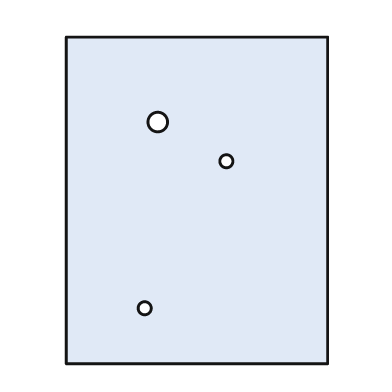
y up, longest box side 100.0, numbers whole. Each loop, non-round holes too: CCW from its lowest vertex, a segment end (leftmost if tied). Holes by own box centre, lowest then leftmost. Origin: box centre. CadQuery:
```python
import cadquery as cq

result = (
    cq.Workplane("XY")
    .moveTo(-40.0, -50.0)
    .lineTo(40.0, -50.0)
    .lineTo(40.0, 50.0)
    .lineTo(-40.0, 50.0)
    .close()
    .moveTo(-16.0, -33.0)
    .circle(2.0)
    .moveTo(9.0, 12.0)
    .circle(2.0)
    .moveTo(-12.0, 24.0)
    .circle(3.0)
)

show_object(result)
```